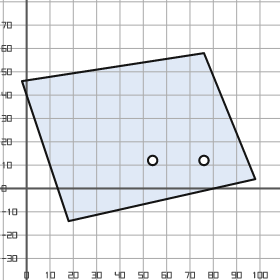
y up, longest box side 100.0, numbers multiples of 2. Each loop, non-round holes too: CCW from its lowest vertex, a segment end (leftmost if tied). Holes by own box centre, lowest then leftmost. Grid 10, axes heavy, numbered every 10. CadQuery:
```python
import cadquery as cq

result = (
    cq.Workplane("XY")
    .moveTo(18.0, -14.0)
    .lineTo(98.0, 4.0)
    .lineTo(76.0, 58.0)
    .lineTo(-2.0, 46.0)
    .close()
    .moveTo(54.0, 12.0)
    .circle(2.0)
    .moveTo(76.0, 12.0)
    .circle(2.0)
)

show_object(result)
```